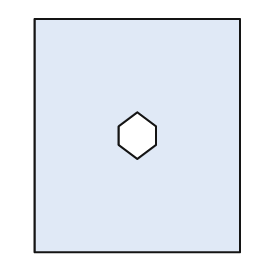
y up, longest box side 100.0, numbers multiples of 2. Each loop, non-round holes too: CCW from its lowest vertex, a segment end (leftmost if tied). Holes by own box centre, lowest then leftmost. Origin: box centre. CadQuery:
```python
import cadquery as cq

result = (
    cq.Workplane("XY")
    .moveTo(-44.0, -50.0)
    .lineTo(44.0, -50.0)
    .lineTo(44.0, 50.0)
    .lineTo(-44.0, 50.0)
    .close()
    .moveTo(0.0, -10.0)
    .lineTo(8.0, -4.0)
    .lineTo(8.0, 4.0)
    .lineTo(0.0, 10.0)
    .lineTo(-8.0, 4.0)
    .lineTo(-8.0, -4.0)
    .close()
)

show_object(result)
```